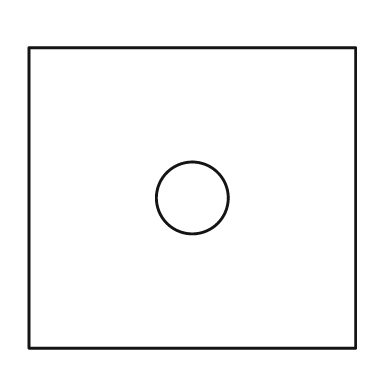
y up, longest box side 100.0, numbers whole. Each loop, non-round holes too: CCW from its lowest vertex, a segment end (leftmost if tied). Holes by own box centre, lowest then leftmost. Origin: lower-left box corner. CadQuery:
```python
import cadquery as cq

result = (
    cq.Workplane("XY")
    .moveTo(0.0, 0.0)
    .lineTo(100.0, 0.0)
    .lineTo(100.0, 92.0)
    .lineTo(0.0, 92.0)
    .close()
    .moveTo(50.0, 46.0)
    .circle(11.0)
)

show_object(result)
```